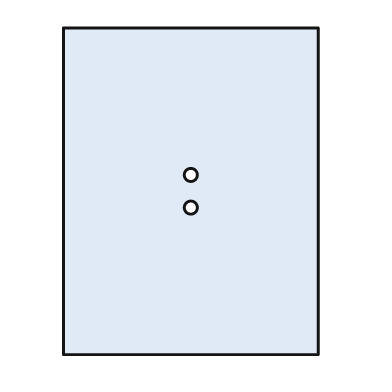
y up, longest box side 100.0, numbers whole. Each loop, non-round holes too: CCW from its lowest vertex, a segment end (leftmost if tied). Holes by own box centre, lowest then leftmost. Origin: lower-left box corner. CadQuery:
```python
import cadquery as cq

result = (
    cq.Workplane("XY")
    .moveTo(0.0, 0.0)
    .lineTo(78.0, 0.0)
    .lineTo(78.0, 100.0)
    .lineTo(0.0, 100.0)
    .close()
    .moveTo(39.0, 45.0)
    .circle(2.0)
    .moveTo(39.0, 55.0)
    .circle(2.0)
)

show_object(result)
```